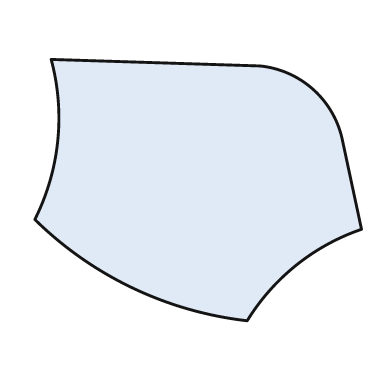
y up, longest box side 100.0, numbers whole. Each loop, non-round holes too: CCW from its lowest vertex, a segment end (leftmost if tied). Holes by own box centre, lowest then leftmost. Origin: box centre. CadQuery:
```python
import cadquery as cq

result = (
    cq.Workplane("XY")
    .moveTo(15.0, -40.0)
    .threePointArc((30.0, -23.0), (50.0, -12.0))
    .lineTo(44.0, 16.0)
    .threePointArc((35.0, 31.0), (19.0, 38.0))
    .lineTo(-45.0, 40.0)
    .threePointArc((-43.0, 15.0), (-50.0, -9.0))
    .threePointArc((-20.0, -30.0), (15.0, -40.0))
    .close()
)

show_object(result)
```